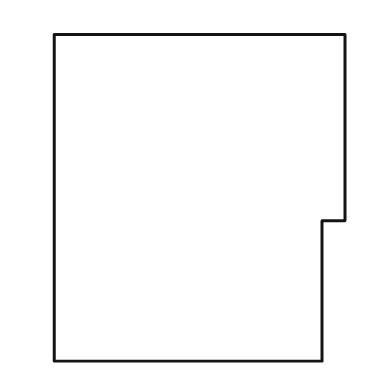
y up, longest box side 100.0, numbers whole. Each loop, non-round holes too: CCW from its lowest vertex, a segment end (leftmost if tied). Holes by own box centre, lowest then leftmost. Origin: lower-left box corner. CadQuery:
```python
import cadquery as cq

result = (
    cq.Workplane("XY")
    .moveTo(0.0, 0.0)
    .lineTo(82.0, 0.0)
    .lineTo(82.0, 43.0)
    .lineTo(89.0, 43.0)
    .lineTo(89.0, 100.0)
    .lineTo(0.0, 100.0)
    .close()
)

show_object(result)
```